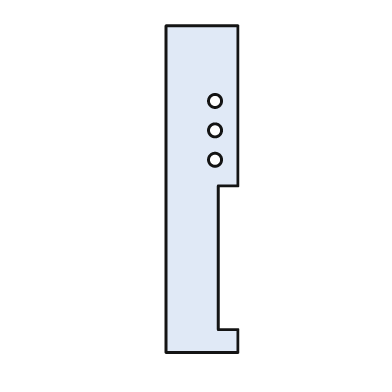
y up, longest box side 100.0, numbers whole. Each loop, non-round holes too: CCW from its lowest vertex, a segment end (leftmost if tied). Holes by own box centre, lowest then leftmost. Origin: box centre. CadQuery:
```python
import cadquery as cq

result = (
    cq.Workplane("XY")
    .moveTo(-11.0, -50.0)
    .lineTo(11.0, -50.0)
    .lineTo(11.0, -43.0)
    .lineTo(5.0, -43.0)
    .lineTo(5.0, 1.0)
    .lineTo(11.0, 1.0)
    .lineTo(11.0, 50.0)
    .lineTo(-11.0, 50.0)
    .close()
    .moveTo(4.0, 9.0)
    .circle(2.0)
    .moveTo(4.0, 18.0)
    .circle(2.0)
    .moveTo(4.0, 27.0)
    .circle(2.0)
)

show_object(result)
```